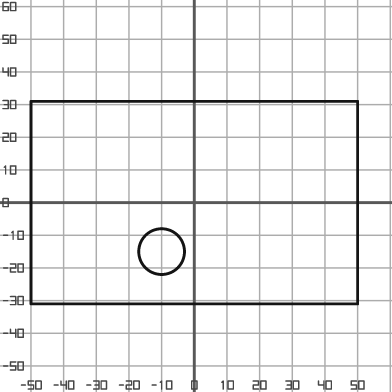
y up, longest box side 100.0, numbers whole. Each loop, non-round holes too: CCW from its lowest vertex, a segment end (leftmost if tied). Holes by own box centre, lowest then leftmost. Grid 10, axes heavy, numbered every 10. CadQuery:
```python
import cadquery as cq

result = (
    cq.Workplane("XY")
    .moveTo(-50.0, -31.0)
    .lineTo(50.0, -31.0)
    .lineTo(50.0, 31.0)
    .lineTo(-50.0, 31.0)
    .close()
    .moveTo(-10.0, -15.0)
    .circle(7.0)
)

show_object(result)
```